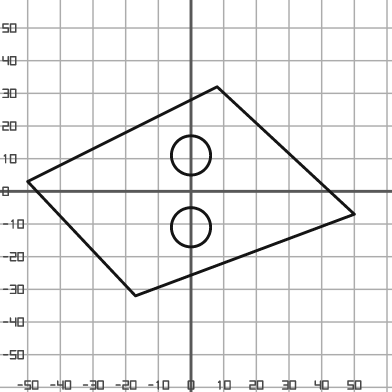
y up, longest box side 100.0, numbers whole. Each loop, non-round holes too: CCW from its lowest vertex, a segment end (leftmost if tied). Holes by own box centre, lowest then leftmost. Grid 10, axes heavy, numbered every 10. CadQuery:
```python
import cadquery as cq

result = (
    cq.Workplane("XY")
    .moveTo(-17.0, -32.0)
    .lineTo(50.0, -7.0)
    .lineTo(8.0, 32.0)
    .lineTo(-50.0, 3.0)
    .close()
    .moveTo(0.0, -11.0)
    .circle(6.0)
    .moveTo(0.0, 11.0)
    .circle(6.0)
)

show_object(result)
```